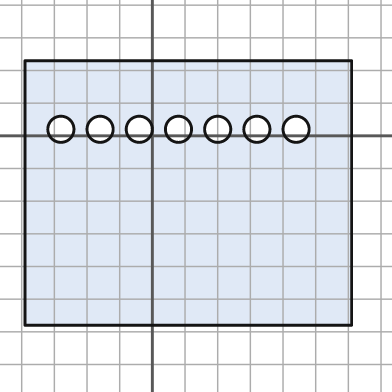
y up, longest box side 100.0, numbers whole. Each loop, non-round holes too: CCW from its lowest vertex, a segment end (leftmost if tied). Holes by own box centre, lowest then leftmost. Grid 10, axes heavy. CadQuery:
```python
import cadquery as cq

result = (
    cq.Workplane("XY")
    .moveTo(-39.0, -58.0)
    .lineTo(61.0, -58.0)
    .lineTo(61.0, 23.0)
    .lineTo(-39.0, 23.0)
    .close()
    .moveTo(-28.0, 2.0)
    .circle(4.0)
    .moveTo(-16.0, 2.0)
    .circle(4.0)
    .moveTo(-4.0, 2.0)
    .circle(4.0)
    .moveTo(8.0, 2.0)
    .circle(4.0)
    .moveTo(20.0, 2.0)
    .circle(4.0)
    .moveTo(32.0, 2.0)
    .circle(4.0)
    .moveTo(44.0, 2.0)
    .circle(4.0)
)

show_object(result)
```